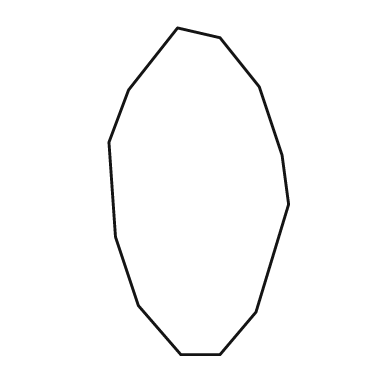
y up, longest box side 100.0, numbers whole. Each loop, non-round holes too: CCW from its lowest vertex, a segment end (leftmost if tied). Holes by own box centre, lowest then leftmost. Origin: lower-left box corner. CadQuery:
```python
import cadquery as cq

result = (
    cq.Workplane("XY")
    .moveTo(22.0, 0.0)
    .lineTo(34.0, 0.0)
    .lineTo(45.0, 13.0)
    .lineTo(55.0, 46.0)
    .lineTo(53.0, 61.0)
    .lineTo(46.0, 82.0)
    .lineTo(34.0, 97.0)
    .lineTo(21.0, 100.0)
    .lineTo(6.0, 81.0)
    .lineTo(0.0, 65.0)
    .lineTo(2.0, 36.0)
    .lineTo(9.0, 15.0)
    .close()
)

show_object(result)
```